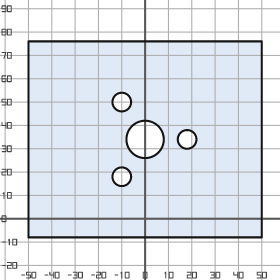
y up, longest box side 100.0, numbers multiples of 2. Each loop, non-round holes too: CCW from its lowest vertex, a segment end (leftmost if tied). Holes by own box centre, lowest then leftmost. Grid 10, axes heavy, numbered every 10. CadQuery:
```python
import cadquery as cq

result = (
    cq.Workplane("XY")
    .moveTo(-50.0, -8.0)
    .lineTo(50.0, -8.0)
    .lineTo(50.0, 76.0)
    .lineTo(-50.0, 76.0)
    .close()
    .moveTo(-10.0, 18.0)
    .circle(4.0)
    .moveTo(0.0, 34.0)
    .circle(8.0)
    .moveTo(18.0, 34.0)
    .circle(4.0)
    .moveTo(-10.0, 50.0)
    .circle(4.0)
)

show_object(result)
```